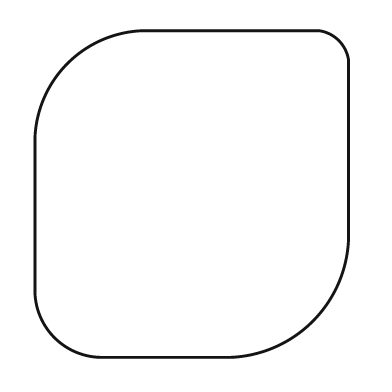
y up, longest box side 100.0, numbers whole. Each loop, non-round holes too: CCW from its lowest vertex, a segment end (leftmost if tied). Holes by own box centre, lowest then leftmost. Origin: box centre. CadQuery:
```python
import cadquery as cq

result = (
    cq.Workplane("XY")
    .moveTo(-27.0, -50.0)
    .lineTo(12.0, -50.0)
    .threePointArc((37.0, -39.0), (48.0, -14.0))
    .lineTo(48.0, 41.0)
    .threePointArc((45.0, 47.0), (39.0, 50.0))
    .lineTo(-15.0, 50.0)
    .threePointArc((-38.0, 40.0), (-48.0, 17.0))
    .lineTo(-48.0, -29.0)
    .threePointArc((-42.0, -44.0), (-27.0, -50.0))
    .close()
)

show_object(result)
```